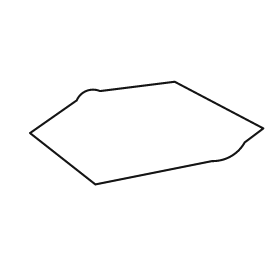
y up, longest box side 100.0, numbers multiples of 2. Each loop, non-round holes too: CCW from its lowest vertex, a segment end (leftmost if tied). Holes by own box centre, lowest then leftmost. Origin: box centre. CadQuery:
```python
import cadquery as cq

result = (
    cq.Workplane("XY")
    .moveTo(-22.0, -22.0)
    .lineTo(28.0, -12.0)
    .threePointArc((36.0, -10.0), (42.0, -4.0))
    .lineTo(50.0, 2.0)
    .lineTo(12.0, 22.0)
    .lineTo(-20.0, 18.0)
    .threePointArc((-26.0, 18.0), (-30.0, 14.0))
    .lineTo(-50.0, 0.0)
    .close()
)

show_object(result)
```